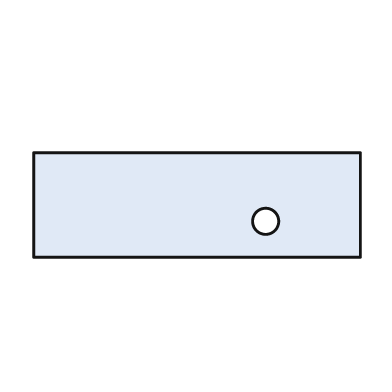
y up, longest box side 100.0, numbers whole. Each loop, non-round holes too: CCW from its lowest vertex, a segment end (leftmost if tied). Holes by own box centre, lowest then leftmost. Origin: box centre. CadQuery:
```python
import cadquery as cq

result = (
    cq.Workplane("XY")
    .moveTo(-50.0, -16.0)
    .lineTo(50.0, -16.0)
    .lineTo(50.0, 16.0)
    .lineTo(-50.0, 16.0)
    .close()
    .moveTo(21.0, -5.0)
    .circle(4.0)
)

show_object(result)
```